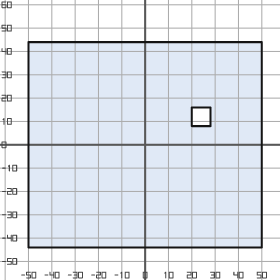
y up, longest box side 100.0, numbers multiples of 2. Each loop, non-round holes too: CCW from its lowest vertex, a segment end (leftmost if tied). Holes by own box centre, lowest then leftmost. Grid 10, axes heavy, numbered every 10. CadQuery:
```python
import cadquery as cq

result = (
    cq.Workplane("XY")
    .moveTo(-50.0, -44.0)
    .lineTo(50.0, -44.0)
    .lineTo(50.0, 44.0)
    .lineTo(-50.0, 44.0)
    .close()
    .moveTo(20.0, 8.0)
    .lineTo(28.0, 8.0)
    .lineTo(28.0, 16.0)
    .lineTo(20.0, 16.0)
    .close()
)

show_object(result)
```